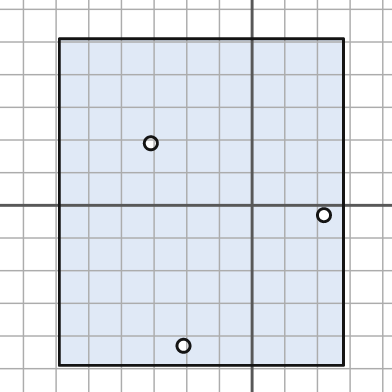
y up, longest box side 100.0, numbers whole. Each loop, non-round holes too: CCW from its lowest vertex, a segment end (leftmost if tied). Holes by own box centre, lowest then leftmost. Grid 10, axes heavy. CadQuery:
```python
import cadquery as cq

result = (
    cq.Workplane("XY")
    .moveTo(-59.0, -49.0)
    .lineTo(28.0, -49.0)
    .lineTo(28.0, 51.0)
    .lineTo(-59.0, 51.0)
    .close()
    .moveTo(-21.0, -43.0)
    .circle(2.0)
    .moveTo(22.0, -3.0)
    .circle(2.0)
    .moveTo(-31.0, 19.0)
    .circle(2.0)
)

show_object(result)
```